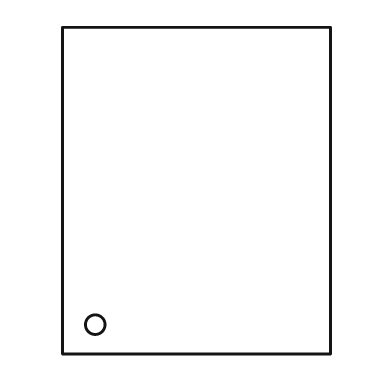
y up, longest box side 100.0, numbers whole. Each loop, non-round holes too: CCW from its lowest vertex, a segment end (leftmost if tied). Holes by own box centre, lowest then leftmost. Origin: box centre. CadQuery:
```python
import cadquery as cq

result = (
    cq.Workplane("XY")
    .moveTo(-41.0, -50.0)
    .lineTo(41.0, -50.0)
    .lineTo(41.0, 50.0)
    .lineTo(-41.0, 50.0)
    .close()
    .moveTo(-31.0, -41.0)
    .circle(3.0)
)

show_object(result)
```